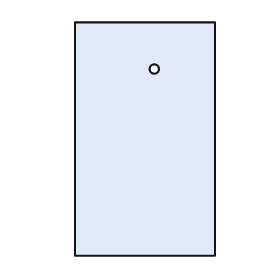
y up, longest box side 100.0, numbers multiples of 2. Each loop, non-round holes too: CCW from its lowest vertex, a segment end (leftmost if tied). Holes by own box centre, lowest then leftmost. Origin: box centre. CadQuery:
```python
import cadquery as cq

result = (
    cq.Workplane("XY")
    .moveTo(-30.0, -50.0)
    .lineTo(30.0, -50.0)
    .lineTo(30.0, 50.0)
    .lineTo(-30.0, 50.0)
    .close()
    .moveTo(4.0, 30.0)
    .circle(2.0)
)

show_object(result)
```